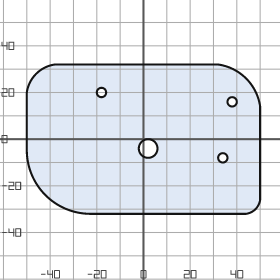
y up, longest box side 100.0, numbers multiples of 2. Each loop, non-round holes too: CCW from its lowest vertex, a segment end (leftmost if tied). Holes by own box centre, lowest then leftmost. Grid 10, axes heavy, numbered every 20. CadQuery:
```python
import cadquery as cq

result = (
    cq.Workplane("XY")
    .moveTo(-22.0, -32.0)
    .lineTo(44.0, -32.0)
    .threePointArc((48.0, -30.0), (50.0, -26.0))
    .lineTo(50.0, 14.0)
    .threePointArc((44.0, 26.0), (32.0, 32.0))
    .lineTo(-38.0, 32.0)
    .threePointArc((-46.0, 28.0), (-50.0, 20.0))
    .lineTo(-50.0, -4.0)
    .threePointArc((-42.0, -24.0), (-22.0, -32.0))
    .close()
    .moveTo(34.0, -8.0)
    .circle(2.0)
    .moveTo(2.0, -4.0)
    .circle(4.0)
    .moveTo(38.0, 16.0)
    .circle(2.0)
    .moveTo(-18.0, 20.0)
    .circle(2.0)
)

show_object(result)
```